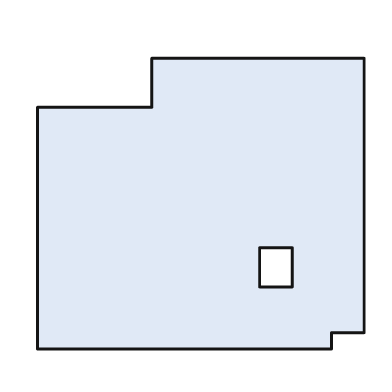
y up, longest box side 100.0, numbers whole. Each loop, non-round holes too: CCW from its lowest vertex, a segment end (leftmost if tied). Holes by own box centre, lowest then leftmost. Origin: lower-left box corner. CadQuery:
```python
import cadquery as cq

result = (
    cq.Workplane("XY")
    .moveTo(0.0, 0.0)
    .lineTo(90.0, 0.0)
    .lineTo(90.0, 5.0)
    .lineTo(100.0, 5.0)
    .lineTo(100.0, 89.0)
    .lineTo(35.0, 89.0)
    .lineTo(35.0, 74.0)
    .lineTo(0.0, 74.0)
    .close()
    .moveTo(68.0, 19.0)
    .lineTo(78.0, 19.0)
    .lineTo(78.0, 31.0)
    .lineTo(68.0, 31.0)
    .close()
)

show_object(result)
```